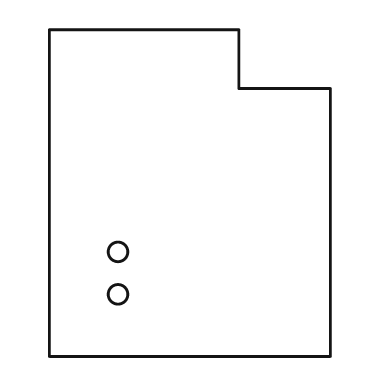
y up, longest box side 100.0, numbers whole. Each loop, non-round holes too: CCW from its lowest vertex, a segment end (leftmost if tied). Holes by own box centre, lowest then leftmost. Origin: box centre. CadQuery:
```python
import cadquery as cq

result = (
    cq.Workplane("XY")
    .moveTo(-43.0, -50.0)
    .lineTo(43.0, -50.0)
    .lineTo(43.0, 32.0)
    .lineTo(15.0, 32.0)
    .lineTo(15.0, 50.0)
    .lineTo(-43.0, 50.0)
    .close()
    .moveTo(-22.0, -31.0)
    .circle(3.0)
    .moveTo(-22.0, -18.0)
    .circle(3.0)
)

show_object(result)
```